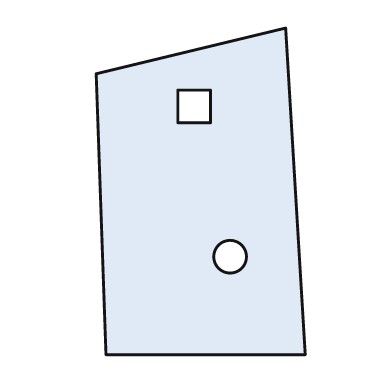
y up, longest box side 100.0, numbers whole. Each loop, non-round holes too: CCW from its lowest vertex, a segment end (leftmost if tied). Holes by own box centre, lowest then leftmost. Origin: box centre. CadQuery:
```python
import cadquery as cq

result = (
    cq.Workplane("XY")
    .moveTo(-29.0, -50.0)
    .lineTo(32.0, -50.0)
    .lineTo(26.0, 50.0)
    .lineTo(-32.0, 36.0)
    .close()
    .moveTo(9.0, -20.0)
    .circle(5.0)
    .moveTo(-7.0, 21.0)
    .lineTo(3.0, 21.0)
    .lineTo(3.0, 31.0)
    .lineTo(-7.0, 31.0)
    .close()
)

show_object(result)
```